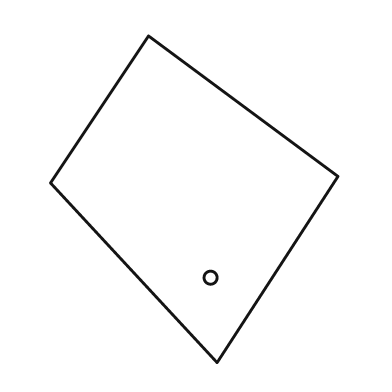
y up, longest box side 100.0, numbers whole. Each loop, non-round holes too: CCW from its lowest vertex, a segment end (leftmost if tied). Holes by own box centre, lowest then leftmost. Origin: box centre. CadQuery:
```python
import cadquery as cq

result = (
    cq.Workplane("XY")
    .moveTo(7.0, -50.0)
    .lineTo(44.0, 7.0)
    .lineTo(-14.0, 50.0)
    .lineTo(-44.0, 5.0)
    .close()
    .moveTo(5.0, -24.0)
    .circle(2.0)
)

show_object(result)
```